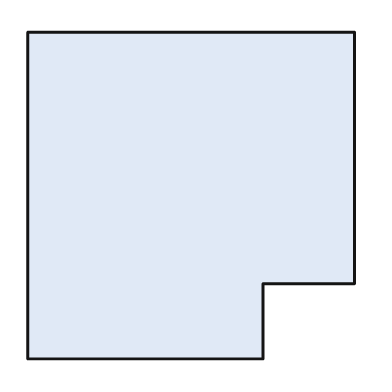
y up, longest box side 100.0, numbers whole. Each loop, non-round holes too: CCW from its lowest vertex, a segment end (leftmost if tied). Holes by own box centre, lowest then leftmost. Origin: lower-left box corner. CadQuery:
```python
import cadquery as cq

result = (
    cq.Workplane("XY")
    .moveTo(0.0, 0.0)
    .lineTo(72.0, 0.0)
    .lineTo(72.0, 23.0)
    .lineTo(100.0, 23.0)
    .lineTo(100.0, 100.0)
    .lineTo(0.0, 100.0)
    .close()
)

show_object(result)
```